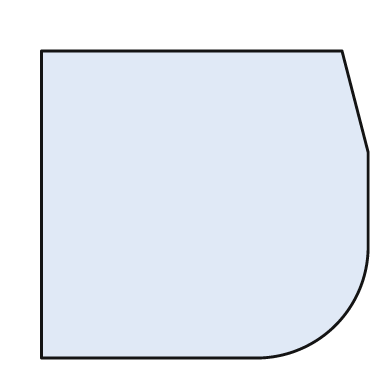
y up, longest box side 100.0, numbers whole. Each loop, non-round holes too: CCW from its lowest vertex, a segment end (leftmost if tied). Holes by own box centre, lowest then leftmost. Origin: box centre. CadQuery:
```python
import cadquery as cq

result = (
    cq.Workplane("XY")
    .moveTo(-50.0, -47.0)
    .lineTo(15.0, -47.0)
    .threePointArc((40.0, -37.0), (50.0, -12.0))
    .lineTo(50.0, 16.0)
    .lineTo(42.0, 47.0)
    .lineTo(-50.0, 47.0)
    .close()
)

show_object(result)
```